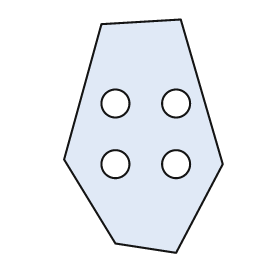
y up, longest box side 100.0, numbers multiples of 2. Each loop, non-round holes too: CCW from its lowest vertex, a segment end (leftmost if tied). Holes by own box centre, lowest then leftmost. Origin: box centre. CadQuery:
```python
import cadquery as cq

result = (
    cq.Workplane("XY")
    .moveTo(14.0, -50.0)
    .lineTo(34.0, -12.0)
    .lineTo(16.0, 50.0)
    .lineTo(-18.0, 48.0)
    .lineTo(-34.0, -10.0)
    .lineTo(-12.0, -46.0)
    .close()
    .moveTo(-12.0, -12.0)
    .circle(6.0)
    .moveTo(14.0, -12.0)
    .circle(6.0)
    .moveTo(-12.0, 14.0)
    .circle(6.0)
    .moveTo(14.0, 14.0)
    .circle(6.0)
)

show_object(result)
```